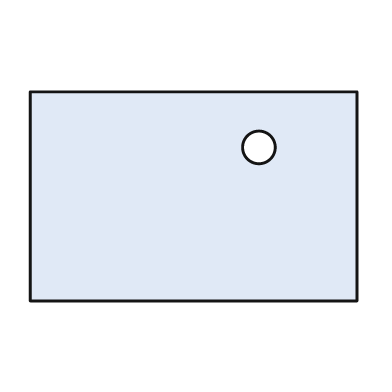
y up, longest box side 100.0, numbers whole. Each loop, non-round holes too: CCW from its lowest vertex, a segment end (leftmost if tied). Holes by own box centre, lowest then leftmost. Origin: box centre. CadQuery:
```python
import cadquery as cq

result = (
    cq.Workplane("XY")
    .moveTo(-50.0, -32.0)
    .lineTo(50.0, -32.0)
    .lineTo(50.0, 32.0)
    .lineTo(-50.0, 32.0)
    .close()
    .moveTo(20.0, 15.0)
    .circle(5.0)
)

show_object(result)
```